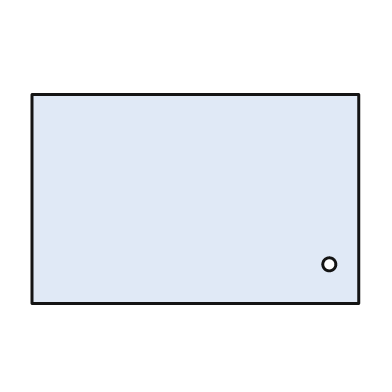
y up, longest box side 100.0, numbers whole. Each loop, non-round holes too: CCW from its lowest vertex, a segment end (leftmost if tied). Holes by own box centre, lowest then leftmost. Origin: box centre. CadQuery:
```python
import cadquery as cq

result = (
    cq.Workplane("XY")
    .moveTo(-50.0, -32.0)
    .lineTo(50.0, -32.0)
    .lineTo(50.0, 32.0)
    .lineTo(-50.0, 32.0)
    .close()
    .moveTo(41.0, -20.0)
    .circle(2.0)
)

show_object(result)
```